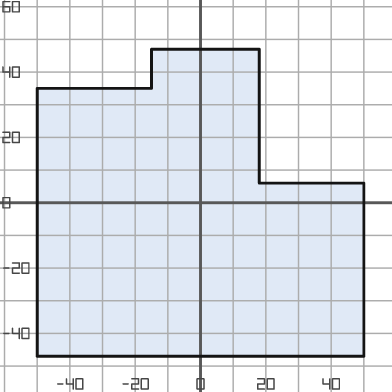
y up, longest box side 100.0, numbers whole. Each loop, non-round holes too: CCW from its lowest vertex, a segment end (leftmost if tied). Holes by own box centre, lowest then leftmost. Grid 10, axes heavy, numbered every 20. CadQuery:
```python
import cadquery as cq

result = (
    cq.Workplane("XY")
    .moveTo(-50.0, -47.0)
    .lineTo(50.0, -47.0)
    .lineTo(50.0, 6.0)
    .lineTo(18.0, 6.0)
    .lineTo(18.0, 47.0)
    .lineTo(-15.0, 47.0)
    .lineTo(-15.0, 35.0)
    .lineTo(-50.0, 35.0)
    .close()
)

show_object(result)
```